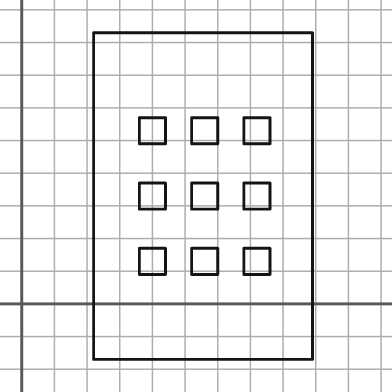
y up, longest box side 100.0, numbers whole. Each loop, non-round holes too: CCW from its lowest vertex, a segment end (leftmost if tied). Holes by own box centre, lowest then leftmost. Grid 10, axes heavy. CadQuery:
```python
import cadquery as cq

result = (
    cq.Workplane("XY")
    .moveTo(22.0, -17.0)
    .lineTo(89.0, -17.0)
    .lineTo(89.0, 83.0)
    .lineTo(22.0, 83.0)
    .close()
    .moveTo(36.0, 9.0)
    .lineTo(44.0, 9.0)
    .lineTo(44.0, 17.0)
    .lineTo(36.0, 17.0)
    .close()
    .moveTo(52.0, 9.0)
    .lineTo(60.0, 9.0)
    .lineTo(60.0, 17.0)
    .lineTo(52.0, 17.0)
    .close()
    .moveTo(68.0, 9.0)
    .lineTo(76.0, 9.0)
    .lineTo(76.0, 17.0)
    .lineTo(68.0, 17.0)
    .close()
    .moveTo(36.0, 29.0)
    .lineTo(44.0, 29.0)
    .lineTo(44.0, 37.0)
    .lineTo(36.0, 37.0)
    .close()
    .moveTo(52.0, 29.0)
    .lineTo(60.0, 29.0)
    .lineTo(60.0, 37.0)
    .lineTo(52.0, 37.0)
    .close()
    .moveTo(68.0, 29.0)
    .lineTo(76.0, 29.0)
    .lineTo(76.0, 37.0)
    .lineTo(68.0, 37.0)
    .close()
    .moveTo(36.0, 49.0)
    .lineTo(44.0, 49.0)
    .lineTo(44.0, 57.0)
    .lineTo(36.0, 57.0)
    .close()
    .moveTo(52.0, 49.0)
    .lineTo(60.0, 49.0)
    .lineTo(60.0, 57.0)
    .lineTo(52.0, 57.0)
    .close()
    .moveTo(68.0, 49.0)
    .lineTo(76.0, 49.0)
    .lineTo(76.0, 57.0)
    .lineTo(68.0, 57.0)
    .close()
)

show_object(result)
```